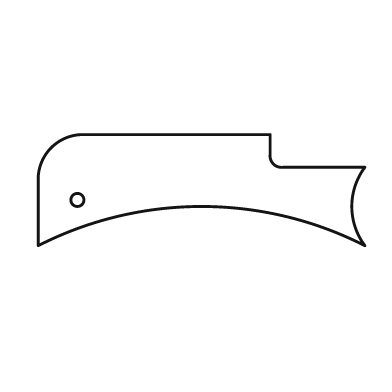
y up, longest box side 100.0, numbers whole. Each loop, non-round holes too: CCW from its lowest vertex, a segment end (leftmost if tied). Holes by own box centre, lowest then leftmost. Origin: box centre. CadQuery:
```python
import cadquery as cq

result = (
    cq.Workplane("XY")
    .moveTo(-50.0, -17.0)
    .threePointArc((0.0, -5.0), (50.0, -17.0))
    .threePointArc((46.0, -5.0), (50.0, 7.0))
    .lineTo(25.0, 7.0)
    .threePointArc((22.0, 8.0), (21.0, 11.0))
    .lineTo(21.0, 17.0)
    .lineTo(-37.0, 17.0)
    .threePointArc((-46.0, 13.0), (-50.0, 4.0))
    .close()
    .moveTo(-38.0, -3.0)
    .circle(2.0)
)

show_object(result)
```